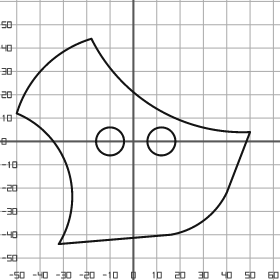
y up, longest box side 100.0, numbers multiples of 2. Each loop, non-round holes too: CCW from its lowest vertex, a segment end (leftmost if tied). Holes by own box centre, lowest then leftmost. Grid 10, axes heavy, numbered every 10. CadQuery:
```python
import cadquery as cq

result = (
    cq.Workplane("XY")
    .moveTo(-32.0, -44.0)
    .lineTo(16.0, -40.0)
    .threePointArc((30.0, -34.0), (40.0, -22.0))
    .lineTo(50.0, 4.0)
    .threePointArc((10.0, 14.0), (-18.0, 44.0))
    .threePointArc((-38.0, 32.0), (-50.0, 12.0))
    .threePointArc((-28.0, -12.0), (-32.0, -44.0))
    .close()
    .moveTo(-10.0, 0.0)
    .circle(6.0)
    .moveTo(12.0, 0.0)
    .circle(6.0)
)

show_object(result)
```